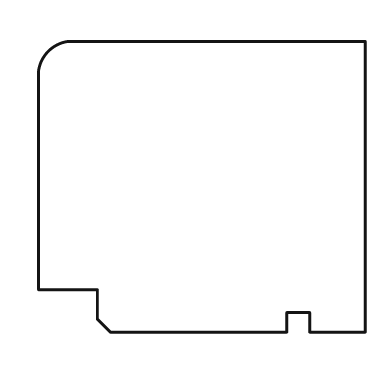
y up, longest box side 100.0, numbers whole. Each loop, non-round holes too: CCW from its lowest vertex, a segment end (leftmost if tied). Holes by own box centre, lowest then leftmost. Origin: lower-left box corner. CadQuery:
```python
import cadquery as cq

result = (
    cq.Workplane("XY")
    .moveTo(22.0, 0.0)
    .lineTo(76.0, 0.0)
    .lineTo(76.0, 6.0)
    .lineTo(83.0, 6.0)
    .lineTo(83.0, 0.0)
    .lineTo(100.0, 0.0)
    .lineTo(100.0, 89.0)
    .lineTo(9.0, 89.0)
    .threePointArc((3.0, 86.0), (0.0, 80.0))
    .lineTo(0.0, 13.0)
    .lineTo(18.0, 13.0)
    .lineTo(18.0, 4.0)
    .close()
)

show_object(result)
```